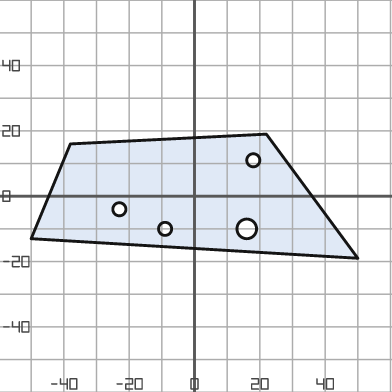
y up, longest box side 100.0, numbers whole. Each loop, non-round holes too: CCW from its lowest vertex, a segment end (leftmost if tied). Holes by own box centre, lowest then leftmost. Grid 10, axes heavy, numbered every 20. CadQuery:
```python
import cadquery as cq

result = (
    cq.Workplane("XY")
    .moveTo(50.0, -19.0)
    .lineTo(22.0, 19.0)
    .lineTo(-38.0, 16.0)
    .lineTo(-50.0, -13.0)
    .close()
    .moveTo(-9.0, -10.0)
    .circle(2.0)
    .moveTo(16.0, -10.0)
    .circle(3.0)
    .moveTo(-23.0, -4.0)
    .circle(2.0)
    .moveTo(18.0, 11.0)
    .circle(2.0)
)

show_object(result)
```